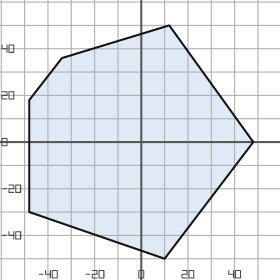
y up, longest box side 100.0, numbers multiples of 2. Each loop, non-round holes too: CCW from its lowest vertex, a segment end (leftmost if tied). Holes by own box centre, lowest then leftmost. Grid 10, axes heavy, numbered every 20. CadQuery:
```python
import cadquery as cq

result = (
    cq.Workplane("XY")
    .moveTo(10.0, -50.0)
    .lineTo(48.0, 0.0)
    .lineTo(12.0, 50.0)
    .lineTo(-34.0, 36.0)
    .lineTo(-48.0, 18.0)
    .lineTo(-48.0, -30.0)
    .close()
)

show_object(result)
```